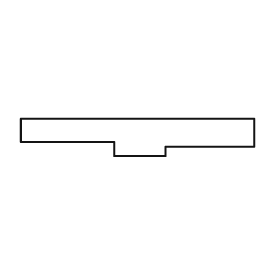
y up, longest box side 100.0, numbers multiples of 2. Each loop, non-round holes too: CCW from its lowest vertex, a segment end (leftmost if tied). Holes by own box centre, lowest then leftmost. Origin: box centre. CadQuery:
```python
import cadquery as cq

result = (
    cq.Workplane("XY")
    .moveTo(-10.0, -8.0)
    .lineTo(12.0, -8.0)
    .lineTo(12.0, -4.0)
    .lineTo(50.0, -4.0)
    .lineTo(50.0, 8.0)
    .lineTo(-50.0, 8.0)
    .lineTo(-50.0, -2.0)
    .lineTo(-10.0, -2.0)
    .close()
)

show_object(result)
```